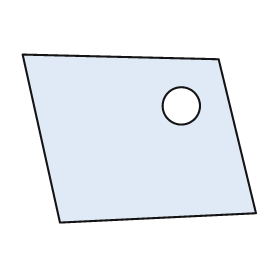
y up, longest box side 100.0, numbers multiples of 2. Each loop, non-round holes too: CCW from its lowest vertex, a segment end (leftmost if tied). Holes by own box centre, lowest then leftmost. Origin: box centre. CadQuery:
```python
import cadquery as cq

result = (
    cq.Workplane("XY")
    .moveTo(-34.0, -36.0)
    .lineTo(50.0, -32.0)
    .lineTo(34.0, 34.0)
    .lineTo(-50.0, 36.0)
    .close()
    .moveTo(18.0, 14.0)
    .circle(8.0)
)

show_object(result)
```